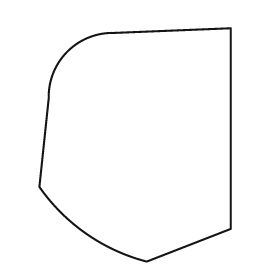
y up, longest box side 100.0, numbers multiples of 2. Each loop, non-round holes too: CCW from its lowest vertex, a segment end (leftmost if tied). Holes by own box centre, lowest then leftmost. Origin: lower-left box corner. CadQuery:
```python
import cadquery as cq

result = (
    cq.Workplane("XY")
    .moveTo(46.0, 0.0)
    .lineTo(82.0, 14.0)
    .lineTo(82.0, 100.0)
    .lineTo(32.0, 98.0)
    .threePointArc((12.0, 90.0), (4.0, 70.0))
    .lineTo(0.0, 32.0)
    .threePointArc((20.0, 12.0), (46.0, 0.0))
    .close()
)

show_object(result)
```